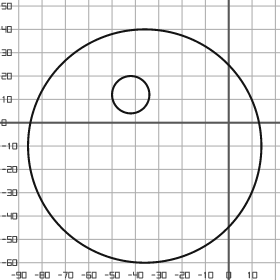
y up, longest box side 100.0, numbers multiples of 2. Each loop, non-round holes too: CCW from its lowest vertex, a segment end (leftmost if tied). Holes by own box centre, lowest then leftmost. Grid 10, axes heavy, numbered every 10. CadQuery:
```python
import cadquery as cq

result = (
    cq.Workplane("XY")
    .moveTo(-36.0, -10.0)
    .circle(50.0)
    .moveTo(-42.0, 12.0)
    .circle(8.0)
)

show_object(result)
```